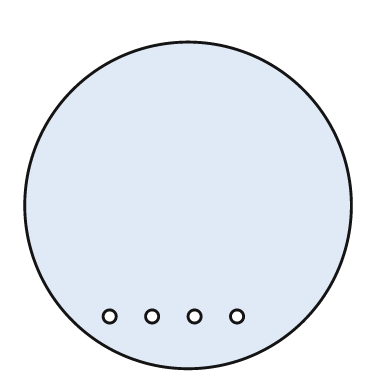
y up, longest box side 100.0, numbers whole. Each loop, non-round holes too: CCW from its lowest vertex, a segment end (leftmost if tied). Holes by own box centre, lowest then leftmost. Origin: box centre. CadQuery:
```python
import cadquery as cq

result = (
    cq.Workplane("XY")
    .moveTo(0.0, 0.0)
    .circle(50.0)
    .moveTo(-24.0, -34.0)
    .circle(2.0)
    .moveTo(-11.0, -34.0)
    .circle(2.0)
    .moveTo(2.0, -34.0)
    .circle(2.0)
    .moveTo(15.0, -34.0)
    .circle(2.0)
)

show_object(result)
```